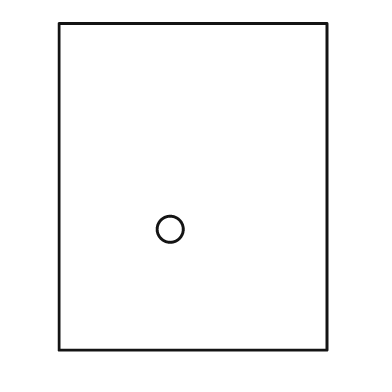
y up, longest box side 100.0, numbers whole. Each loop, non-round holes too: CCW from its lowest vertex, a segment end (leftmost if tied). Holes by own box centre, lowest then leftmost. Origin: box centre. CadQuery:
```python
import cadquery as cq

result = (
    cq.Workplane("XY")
    .moveTo(-41.0, -50.0)
    .lineTo(41.0, -50.0)
    .lineTo(41.0, 50.0)
    .lineTo(-41.0, 50.0)
    .close()
    .moveTo(-7.0, -13.0)
    .circle(4.0)
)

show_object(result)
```